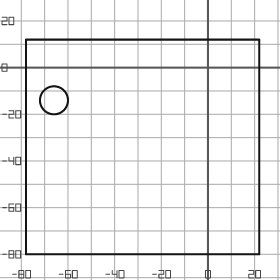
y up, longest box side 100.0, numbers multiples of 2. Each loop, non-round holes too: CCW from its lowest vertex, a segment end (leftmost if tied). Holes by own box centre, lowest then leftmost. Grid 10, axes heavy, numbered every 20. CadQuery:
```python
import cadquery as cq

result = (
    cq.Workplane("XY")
    .moveTo(-78.0, -80.0)
    .lineTo(22.0, -80.0)
    .lineTo(22.0, 12.0)
    .lineTo(-78.0, 12.0)
    .close()
    .moveTo(-66.0, -14.0)
    .circle(6.0)
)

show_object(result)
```